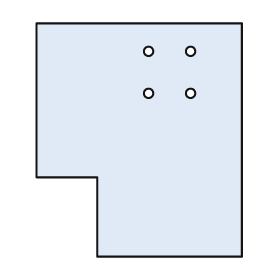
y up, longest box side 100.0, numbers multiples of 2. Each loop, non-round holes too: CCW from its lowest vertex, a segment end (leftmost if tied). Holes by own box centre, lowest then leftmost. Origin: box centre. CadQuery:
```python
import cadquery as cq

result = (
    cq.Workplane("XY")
    .moveTo(-18.0, -50.0)
    .lineTo(44.0, -50.0)
    .lineTo(44.0, 50.0)
    .lineTo(-44.0, 50.0)
    .lineTo(-44.0, -16.0)
    .lineTo(-18.0, -16.0)
    .close()
    .moveTo(4.0, 20.0)
    .circle(2.0)
    .moveTo(22.0, 20.0)
    .circle(2.0)
    .moveTo(4.0, 38.0)
    .circle(2.0)
    .moveTo(22.0, 38.0)
    .circle(2.0)
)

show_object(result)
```